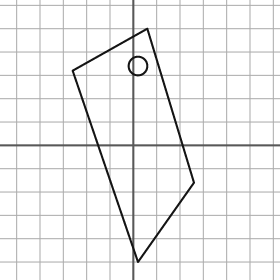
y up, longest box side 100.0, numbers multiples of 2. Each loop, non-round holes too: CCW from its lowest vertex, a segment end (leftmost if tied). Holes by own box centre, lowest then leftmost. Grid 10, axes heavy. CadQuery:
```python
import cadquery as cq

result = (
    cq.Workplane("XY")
    .moveTo(2.0, -50.0)
    .lineTo(26.0, -16.0)
    .lineTo(6.0, 50.0)
    .lineTo(-26.0, 32.0)
    .close()
    .moveTo(2.0, 34.0)
    .circle(4.0)
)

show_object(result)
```